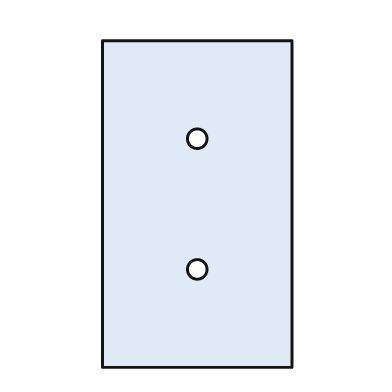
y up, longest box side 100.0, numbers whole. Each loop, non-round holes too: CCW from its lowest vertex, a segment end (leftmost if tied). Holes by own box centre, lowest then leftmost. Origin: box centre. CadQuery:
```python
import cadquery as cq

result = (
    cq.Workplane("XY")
    .moveTo(-29.0, -50.0)
    .lineTo(29.0, -50.0)
    .lineTo(29.0, 50.0)
    .lineTo(-29.0, 50.0)
    .close()
    .moveTo(0.0, -20.0)
    .circle(3.0)
    .moveTo(0.0, 20.0)
    .circle(3.0)
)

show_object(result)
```